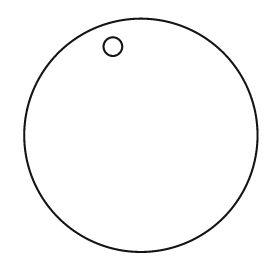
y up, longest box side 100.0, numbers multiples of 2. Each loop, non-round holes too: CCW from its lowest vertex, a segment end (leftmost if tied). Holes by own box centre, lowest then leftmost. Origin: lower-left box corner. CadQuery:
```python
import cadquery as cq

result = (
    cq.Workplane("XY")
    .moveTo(50.0, 50.0)
    .circle(50.0)
    .moveTo(38.0, 88.0)
    .circle(4.0)
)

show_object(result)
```